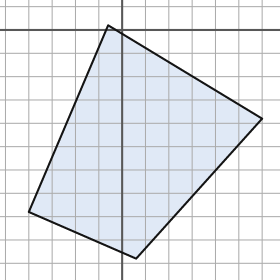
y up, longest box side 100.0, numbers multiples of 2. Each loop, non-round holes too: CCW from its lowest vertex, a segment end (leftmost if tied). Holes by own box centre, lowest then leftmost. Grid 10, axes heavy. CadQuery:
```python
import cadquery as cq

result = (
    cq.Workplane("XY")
    .moveTo(6.0, -98.0)
    .lineTo(60.0, -38.0)
    .lineTo(-6.0, 2.0)
    .lineTo(-40.0, -78.0)
    .close()
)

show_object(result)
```